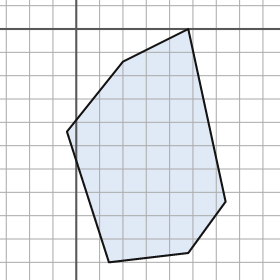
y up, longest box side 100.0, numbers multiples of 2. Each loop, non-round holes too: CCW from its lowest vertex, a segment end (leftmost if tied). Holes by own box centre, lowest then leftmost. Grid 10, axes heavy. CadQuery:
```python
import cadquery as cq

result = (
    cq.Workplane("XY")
    .moveTo(14.0, -100.0)
    .lineTo(48.0, -96.0)
    .lineTo(64.0, -74.0)
    .lineTo(48.0, 0.0)
    .lineTo(20.0, -14.0)
    .lineTo(-4.0, -44.0)
    .close()
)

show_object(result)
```